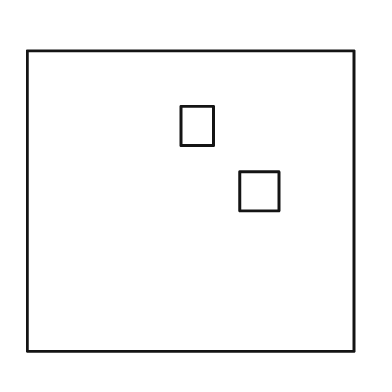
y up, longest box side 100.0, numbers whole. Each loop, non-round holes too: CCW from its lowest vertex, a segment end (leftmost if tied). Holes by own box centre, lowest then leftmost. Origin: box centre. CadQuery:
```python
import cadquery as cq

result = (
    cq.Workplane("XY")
    .moveTo(-50.0, -46.0)
    .lineTo(50.0, -46.0)
    .lineTo(50.0, 46.0)
    .lineTo(-50.0, 46.0)
    .close()
    .moveTo(15.0, -3.0)
    .lineTo(27.0, -3.0)
    .lineTo(27.0, 9.0)
    .lineTo(15.0, 9.0)
    .close()
    .moveTo(-3.0, 17.0)
    .lineTo(7.0, 17.0)
    .lineTo(7.0, 29.0)
    .lineTo(-3.0, 29.0)
    .close()
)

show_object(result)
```